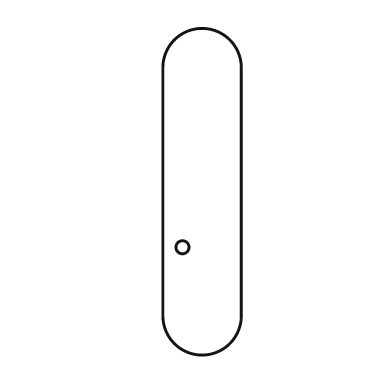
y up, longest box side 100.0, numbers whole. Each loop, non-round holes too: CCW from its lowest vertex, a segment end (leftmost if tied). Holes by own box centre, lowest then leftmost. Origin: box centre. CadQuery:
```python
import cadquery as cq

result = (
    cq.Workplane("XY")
    .moveTo(-12.0, -38.0)
    .threePointArc((0.0, -50.0), (12.0, -38.0))
    .lineTo(12.0, 38.0)
    .threePointArc((0.0, 50.0), (-12.0, 38.0))
    .close()
    .moveTo(-6.0, -17.0)
    .circle(2.0)
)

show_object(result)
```